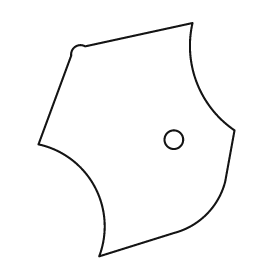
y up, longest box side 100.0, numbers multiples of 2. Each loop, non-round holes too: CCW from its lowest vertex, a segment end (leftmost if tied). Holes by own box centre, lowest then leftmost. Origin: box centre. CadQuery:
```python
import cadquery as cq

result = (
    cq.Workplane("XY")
    .moveTo(-16.0, -50.0)
    .lineTo(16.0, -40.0)
    .threePointArc((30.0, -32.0), (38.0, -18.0))
    .lineTo(42.0, 4.0)
    .threePointArc((26.0, 24.0), (24.0, 50.0))
    .lineTo(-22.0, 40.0)
    .threePointArc((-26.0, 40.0), (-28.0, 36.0))
    .lineTo(-42.0, -2.0)
    .threePointArc((-18.0, -20.0), (-16.0, -50.0))
    .close()
    .moveTo(16.0, 0.0)
    .circle(4.0)
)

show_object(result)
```